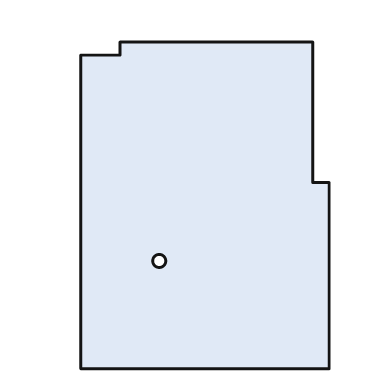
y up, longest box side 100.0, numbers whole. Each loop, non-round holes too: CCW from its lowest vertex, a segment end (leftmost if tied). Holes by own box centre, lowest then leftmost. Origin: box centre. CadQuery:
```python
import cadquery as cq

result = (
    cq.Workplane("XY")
    .moveTo(-38.0, -50.0)
    .lineTo(38.0, -50.0)
    .lineTo(38.0, 7.0)
    .lineTo(33.0, 7.0)
    .lineTo(33.0, 50.0)
    .lineTo(-26.0, 50.0)
    .lineTo(-26.0, 46.0)
    .lineTo(-38.0, 46.0)
    .close()
    .moveTo(-14.0, -17.0)
    .circle(2.0)
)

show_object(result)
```